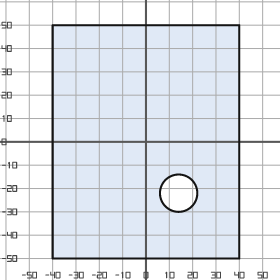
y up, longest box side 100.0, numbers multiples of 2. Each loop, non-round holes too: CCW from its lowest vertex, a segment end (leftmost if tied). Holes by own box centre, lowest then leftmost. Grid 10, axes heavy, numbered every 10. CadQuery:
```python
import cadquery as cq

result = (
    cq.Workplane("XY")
    .moveTo(-40.0, -50.0)
    .lineTo(40.0, -50.0)
    .lineTo(40.0, 50.0)
    .lineTo(-40.0, 50.0)
    .close()
    .moveTo(14.0, -22.0)
    .circle(8.0)
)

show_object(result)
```